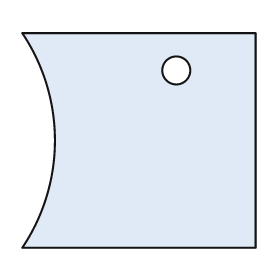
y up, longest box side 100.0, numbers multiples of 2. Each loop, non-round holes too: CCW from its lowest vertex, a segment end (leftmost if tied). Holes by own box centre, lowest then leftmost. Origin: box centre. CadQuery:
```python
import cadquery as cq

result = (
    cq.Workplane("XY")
    .moveTo(-50.0, -46.0)
    .lineTo(50.0, -46.0)
    .lineTo(50.0, 46.0)
    .lineTo(-50.0, 46.0)
    .threePointArc((-36.0, 0.0), (-50.0, -46.0))
    .close()
    .moveTo(16.0, 30.0)
    .circle(6.0)
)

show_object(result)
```